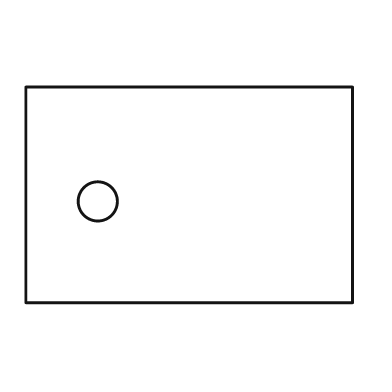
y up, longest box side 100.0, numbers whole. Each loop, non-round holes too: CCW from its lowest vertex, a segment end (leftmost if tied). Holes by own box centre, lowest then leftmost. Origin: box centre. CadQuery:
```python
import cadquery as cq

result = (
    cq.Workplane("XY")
    .moveTo(-50.0, -33.0)
    .lineTo(50.0, -33.0)
    .lineTo(50.0, 33.0)
    .lineTo(-50.0, 33.0)
    .close()
    .moveTo(-28.0, -2.0)
    .circle(6.0)
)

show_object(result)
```